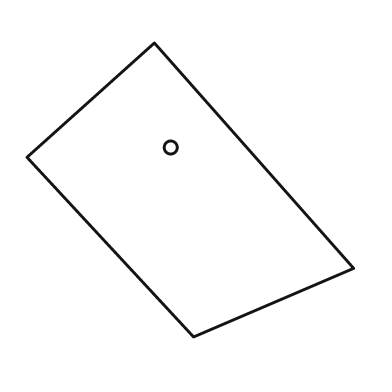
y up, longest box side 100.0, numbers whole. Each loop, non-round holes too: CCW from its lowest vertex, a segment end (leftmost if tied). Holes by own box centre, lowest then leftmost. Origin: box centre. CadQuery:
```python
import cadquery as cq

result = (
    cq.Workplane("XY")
    .moveTo(1.0, -45.0)
    .lineTo(50.0, -24.0)
    .lineTo(-11.0, 45.0)
    .lineTo(-50.0, 10.0)
    .close()
    .moveTo(-6.0, 13.0)
    .circle(2.0)
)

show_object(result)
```